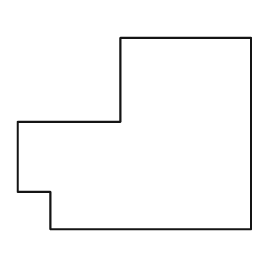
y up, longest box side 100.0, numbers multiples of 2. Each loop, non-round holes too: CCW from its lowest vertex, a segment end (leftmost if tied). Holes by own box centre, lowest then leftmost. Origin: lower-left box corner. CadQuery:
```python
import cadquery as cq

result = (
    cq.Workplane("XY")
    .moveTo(14.0, 0.0)
    .lineTo(100.0, 0.0)
    .lineTo(100.0, 82.0)
    .lineTo(44.0, 82.0)
    .lineTo(44.0, 46.0)
    .lineTo(0.0, 46.0)
    .lineTo(0.0, 16.0)
    .lineTo(14.0, 16.0)
    .close()
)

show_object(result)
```